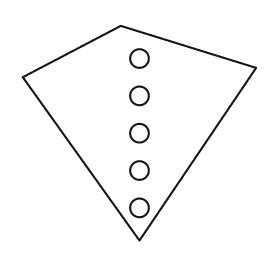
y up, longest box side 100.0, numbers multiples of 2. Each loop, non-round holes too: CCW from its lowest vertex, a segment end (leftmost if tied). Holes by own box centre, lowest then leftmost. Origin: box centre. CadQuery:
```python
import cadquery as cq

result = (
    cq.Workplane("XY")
    .moveTo(0.0, -46.0)
    .lineTo(50.0, 28.0)
    .lineTo(-8.0, 46.0)
    .lineTo(-50.0, 24.0)
    .close()
    .moveTo(0.0, -32.0)
    .circle(4.0)
    .moveTo(0.0, -16.0)
    .circle(4.0)
    .moveTo(0.0, 0.0)
    .circle(4.0)
    .moveTo(0.0, 16.0)
    .circle(4.0)
    .moveTo(0.0, 32.0)
    .circle(4.0)
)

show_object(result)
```